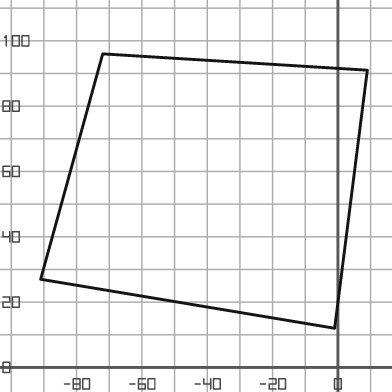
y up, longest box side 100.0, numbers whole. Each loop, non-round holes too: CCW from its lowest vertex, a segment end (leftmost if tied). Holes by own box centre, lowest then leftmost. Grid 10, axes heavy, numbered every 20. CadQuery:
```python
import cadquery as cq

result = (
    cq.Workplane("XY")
    .moveTo(-1.0, 12.0)
    .lineTo(9.0, 91.0)
    .lineTo(-72.0, 96.0)
    .lineTo(-91.0, 27.0)
    .close()
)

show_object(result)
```